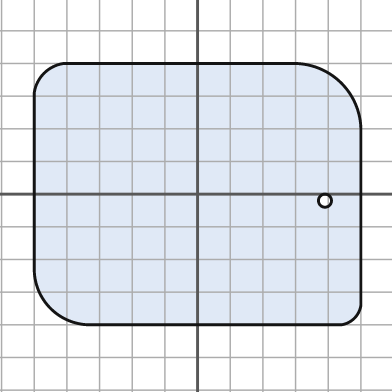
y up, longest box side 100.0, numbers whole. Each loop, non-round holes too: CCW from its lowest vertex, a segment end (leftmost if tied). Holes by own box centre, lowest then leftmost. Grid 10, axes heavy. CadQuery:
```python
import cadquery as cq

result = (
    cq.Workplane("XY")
    .moveTo(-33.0, -40.0)
    .lineTo(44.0, -40.0)
    .threePointArc((48.0, -38.0), (50.0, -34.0))
    .lineTo(50.0, 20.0)
    .threePointArc((44.0, 34.0), (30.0, 40.0))
    .lineTo(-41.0, 40.0)
    .threePointArc((-47.0, 37.0), (-50.0, 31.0))
    .lineTo(-50.0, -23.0)
    .threePointArc((-45.0, -35.0), (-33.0, -40.0))
    .close()
    .moveTo(39.0, -2.0)
    .circle(2.0)
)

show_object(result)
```